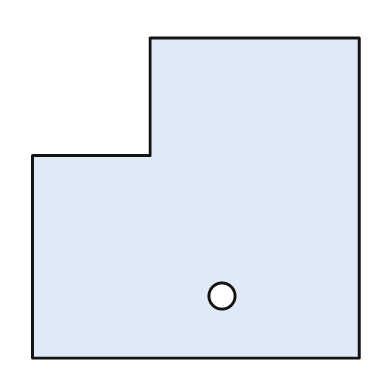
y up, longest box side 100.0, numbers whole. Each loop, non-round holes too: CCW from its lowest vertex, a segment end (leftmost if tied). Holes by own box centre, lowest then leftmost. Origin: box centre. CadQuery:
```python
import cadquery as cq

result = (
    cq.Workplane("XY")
    .moveTo(-50.0, -49.0)
    .lineTo(50.0, -49.0)
    .lineTo(50.0, 49.0)
    .lineTo(-14.0, 49.0)
    .lineTo(-14.0, 13.0)
    .lineTo(-50.0, 13.0)
    .close()
    .moveTo(8.0, -30.0)
    .circle(4.0)
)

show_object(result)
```